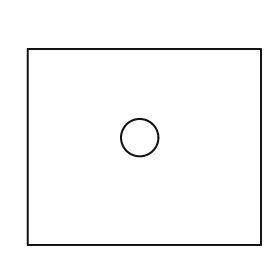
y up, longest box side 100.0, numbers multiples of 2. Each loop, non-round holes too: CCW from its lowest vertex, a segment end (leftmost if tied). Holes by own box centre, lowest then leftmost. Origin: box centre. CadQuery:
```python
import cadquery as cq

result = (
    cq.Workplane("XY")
    .moveTo(-50.0, -42.0)
    .lineTo(50.0, -42.0)
    .lineTo(50.0, 42.0)
    .lineTo(-50.0, 42.0)
    .close()
    .moveTo(-2.0, 4.0)
    .circle(8.0)
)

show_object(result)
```